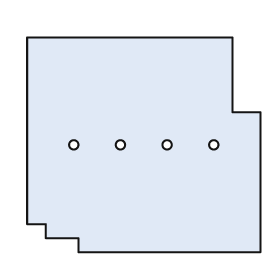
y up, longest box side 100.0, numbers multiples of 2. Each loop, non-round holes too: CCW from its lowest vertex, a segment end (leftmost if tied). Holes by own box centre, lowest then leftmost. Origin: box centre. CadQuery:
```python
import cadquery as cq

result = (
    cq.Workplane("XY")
    .moveTo(-28.0, -46.0)
    .lineTo(50.0, -46.0)
    .lineTo(50.0, 14.0)
    .lineTo(38.0, 14.0)
    .lineTo(38.0, 46.0)
    .lineTo(-50.0, 46.0)
    .lineTo(-50.0, -34.0)
    .lineTo(-42.0, -34.0)
    .lineTo(-42.0, -40.0)
    .lineTo(-28.0, -40.0)
    .close()
    .moveTo(-30.0, 0.0)
    .circle(2.0)
    .moveTo(-10.0, 0.0)
    .circle(2.0)
    .moveTo(10.0, 0.0)
    .circle(2.0)
    .moveTo(30.0, 0.0)
    .circle(2.0)
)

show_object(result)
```